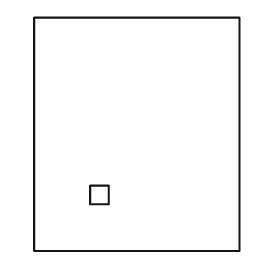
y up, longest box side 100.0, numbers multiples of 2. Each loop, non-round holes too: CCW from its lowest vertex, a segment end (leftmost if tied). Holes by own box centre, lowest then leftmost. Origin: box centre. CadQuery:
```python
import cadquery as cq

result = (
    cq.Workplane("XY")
    .moveTo(-44.0, -50.0)
    .lineTo(44.0, -50.0)
    .lineTo(44.0, 50.0)
    .lineTo(-44.0, 50.0)
    .close()
    .moveTo(-20.0, -30.0)
    .lineTo(-12.0, -30.0)
    .lineTo(-12.0, -22.0)
    .lineTo(-20.0, -22.0)
    .close()
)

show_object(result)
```